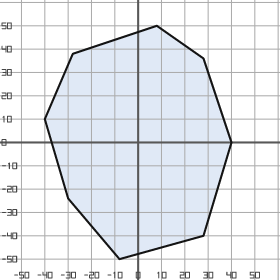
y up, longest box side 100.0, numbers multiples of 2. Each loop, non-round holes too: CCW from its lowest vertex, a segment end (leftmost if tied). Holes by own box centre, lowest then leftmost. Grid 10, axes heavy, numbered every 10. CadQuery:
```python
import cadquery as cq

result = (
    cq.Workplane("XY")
    .moveTo(-8.0, -50.0)
    .lineTo(28.0, -40.0)
    .lineTo(40.0, 0.0)
    .lineTo(28.0, 36.0)
    .lineTo(8.0, 50.0)
    .lineTo(-28.0, 38.0)
    .lineTo(-40.0, 10.0)
    .lineTo(-30.0, -24.0)
    .close()
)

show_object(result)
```